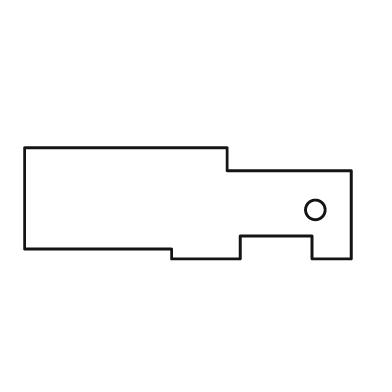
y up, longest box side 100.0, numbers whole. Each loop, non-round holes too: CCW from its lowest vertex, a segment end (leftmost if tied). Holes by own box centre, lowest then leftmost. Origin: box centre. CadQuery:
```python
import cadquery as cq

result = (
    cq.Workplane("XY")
    .moveTo(-5.0, -17.0)
    .lineTo(16.0, -17.0)
    .lineTo(16.0, -10.0)
    .lineTo(38.0, -10.0)
    .lineTo(38.0, -17.0)
    .lineTo(50.0, -17.0)
    .lineTo(50.0, 10.0)
    .lineTo(12.0, 10.0)
    .lineTo(12.0, 17.0)
    .lineTo(-50.0, 17.0)
    .lineTo(-50.0, -14.0)
    .lineTo(-5.0, -14.0)
    .close()
    .moveTo(39.0, -2.0)
    .circle(3.0)
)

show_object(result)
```